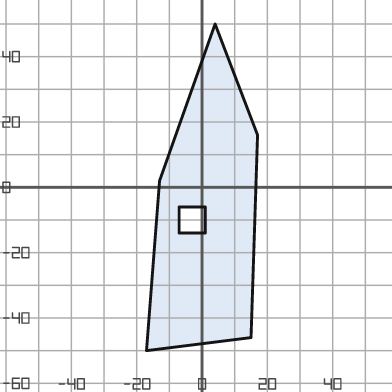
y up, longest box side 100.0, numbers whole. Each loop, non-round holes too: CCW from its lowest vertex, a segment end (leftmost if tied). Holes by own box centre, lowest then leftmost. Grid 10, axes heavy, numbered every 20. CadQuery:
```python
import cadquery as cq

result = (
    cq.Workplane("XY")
    .moveTo(-17.0, -50.0)
    .lineTo(15.0, -46.0)
    .lineTo(17.0, 16.0)
    .lineTo(4.0, 50.0)
    .lineTo(-13.0, 2.0)
    .close()
    .moveTo(-7.0, -14.0)
    .lineTo(1.0, -14.0)
    .lineTo(1.0, -6.0)
    .lineTo(-7.0, -6.0)
    .close()
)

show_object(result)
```